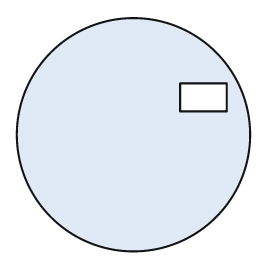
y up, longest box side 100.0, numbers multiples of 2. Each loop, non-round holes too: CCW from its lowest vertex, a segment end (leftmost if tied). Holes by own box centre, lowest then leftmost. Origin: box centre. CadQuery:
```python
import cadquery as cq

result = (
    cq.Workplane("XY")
    .moveTo(0.0, 0.0)
    .circle(50.0)
    .moveTo(20.0, 10.0)
    .lineTo(40.0, 10.0)
    .lineTo(40.0, 22.0)
    .lineTo(20.0, 22.0)
    .close()
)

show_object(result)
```